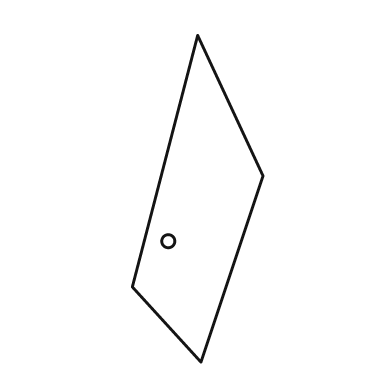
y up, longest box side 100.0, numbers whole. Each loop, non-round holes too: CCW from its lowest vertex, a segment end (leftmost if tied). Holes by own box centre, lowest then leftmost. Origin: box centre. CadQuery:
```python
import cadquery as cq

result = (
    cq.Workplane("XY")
    .moveTo(1.0, -50.0)
    .lineTo(20.0, 7.0)
    .lineTo(0.0, 50.0)
    .lineTo(-20.0, -27.0)
    .close()
    .moveTo(-9.0, -13.0)
    .circle(2.0)
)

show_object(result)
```